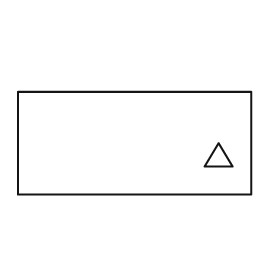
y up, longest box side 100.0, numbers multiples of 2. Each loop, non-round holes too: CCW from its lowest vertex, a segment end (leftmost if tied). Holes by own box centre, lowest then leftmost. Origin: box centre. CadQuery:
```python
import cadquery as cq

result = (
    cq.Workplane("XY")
    .moveTo(-50.0, -22.0)
    .lineTo(50.0, -22.0)
    .lineTo(50.0, 22.0)
    .lineTo(-50.0, 22.0)
    .close()
    .moveTo(30.0, -10.0)
    .lineTo(42.0, -10.0)
    .lineTo(36.0, 0.0)
    .close()
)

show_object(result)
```